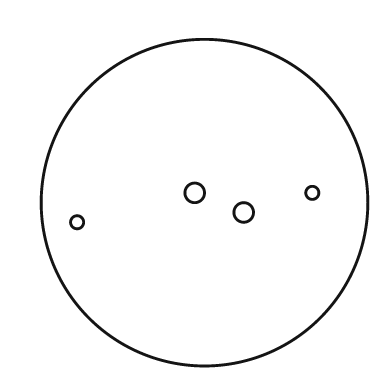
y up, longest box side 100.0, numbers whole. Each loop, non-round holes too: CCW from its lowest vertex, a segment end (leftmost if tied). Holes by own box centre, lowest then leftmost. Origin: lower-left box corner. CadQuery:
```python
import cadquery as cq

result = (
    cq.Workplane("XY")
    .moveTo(50.0, 50.0)
    .circle(50.0)
    .moveTo(11.0, 44.0)
    .circle(2.0)
    .moveTo(62.0, 47.0)
    .circle(3.0)
    .moveTo(47.0, 53.0)
    .circle(3.0)
    .moveTo(83.0, 53.0)
    .circle(2.0)
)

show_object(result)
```